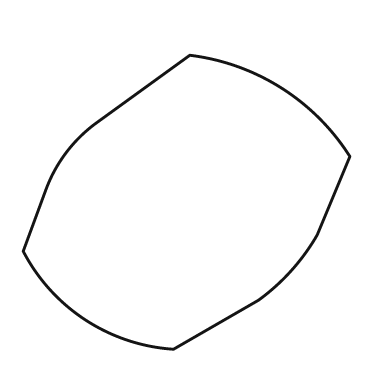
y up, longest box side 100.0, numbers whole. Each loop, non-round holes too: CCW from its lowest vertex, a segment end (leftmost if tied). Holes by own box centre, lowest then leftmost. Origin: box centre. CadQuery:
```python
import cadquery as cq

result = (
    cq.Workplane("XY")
    .moveTo(-4.0, -45.0)
    .lineTo(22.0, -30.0)
    .threePointArc((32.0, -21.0), (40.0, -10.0))
    .lineTo(50.0, 14.0)
    .threePointArc((29.0, 35.0), (1.0, 45.0))
    .lineTo(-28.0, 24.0)
    .threePointArc((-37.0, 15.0), (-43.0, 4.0))
    .lineTo(-50.0, -15.0)
    .threePointArc((-31.0, -36.0), (-4.0, -45.0))
    .close()
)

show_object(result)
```